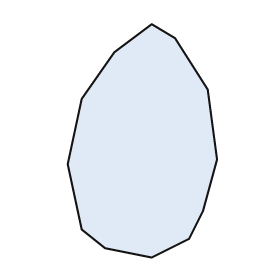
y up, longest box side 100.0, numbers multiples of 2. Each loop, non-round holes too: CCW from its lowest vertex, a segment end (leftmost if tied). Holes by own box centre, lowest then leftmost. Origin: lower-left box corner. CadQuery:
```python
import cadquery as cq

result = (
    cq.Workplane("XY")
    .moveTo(36.0, 0.0)
    .lineTo(52.0, 8.0)
    .lineTo(58.0, 20.0)
    .lineTo(64.0, 42.0)
    .lineTo(60.0, 72.0)
    .lineTo(46.0, 94.0)
    .lineTo(36.0, 100.0)
    .lineTo(20.0, 88.0)
    .lineTo(6.0, 68.0)
    .lineTo(0.0, 40.0)
    .lineTo(6.0, 12.0)
    .lineTo(16.0, 4.0)
    .close()
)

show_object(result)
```